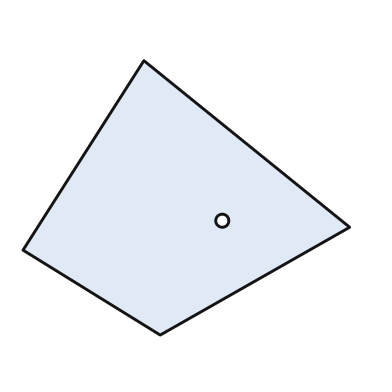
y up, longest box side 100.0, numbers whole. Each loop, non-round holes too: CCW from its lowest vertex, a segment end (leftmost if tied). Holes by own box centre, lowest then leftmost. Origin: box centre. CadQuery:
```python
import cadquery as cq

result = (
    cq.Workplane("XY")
    .moveTo(-8.0, -42.0)
    .lineTo(50.0, -9.0)
    .lineTo(-13.0, 42.0)
    .lineTo(-50.0, -16.0)
    .close()
    .moveTo(11.0, -7.0)
    .circle(2.0)
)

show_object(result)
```